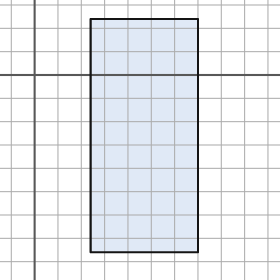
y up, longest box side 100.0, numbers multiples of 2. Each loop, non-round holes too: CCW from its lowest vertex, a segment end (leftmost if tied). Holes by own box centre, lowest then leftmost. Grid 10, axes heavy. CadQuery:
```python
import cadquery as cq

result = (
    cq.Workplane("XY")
    .moveTo(24.0, -76.0)
    .lineTo(70.0, -76.0)
    .lineTo(70.0, 24.0)
    .lineTo(24.0, 24.0)
    .close()
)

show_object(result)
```